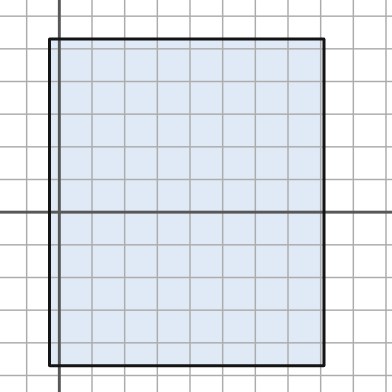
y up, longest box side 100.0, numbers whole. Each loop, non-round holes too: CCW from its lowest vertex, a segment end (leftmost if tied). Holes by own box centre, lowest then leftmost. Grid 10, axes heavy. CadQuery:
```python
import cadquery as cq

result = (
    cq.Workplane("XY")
    .moveTo(-3.0, -47.0)
    .lineTo(81.0, -47.0)
    .lineTo(81.0, 53.0)
    .lineTo(-3.0, 53.0)
    .close()
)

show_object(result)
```